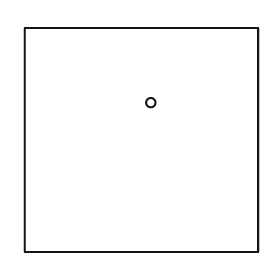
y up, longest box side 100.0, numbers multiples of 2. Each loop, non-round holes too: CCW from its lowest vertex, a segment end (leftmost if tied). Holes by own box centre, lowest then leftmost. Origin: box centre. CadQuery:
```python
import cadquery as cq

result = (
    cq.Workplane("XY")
    .moveTo(-50.0, -48.0)
    .lineTo(50.0, -48.0)
    .lineTo(50.0, 48.0)
    .lineTo(-50.0, 48.0)
    .close()
    .moveTo(4.0, 16.0)
    .circle(2.0)
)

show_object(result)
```